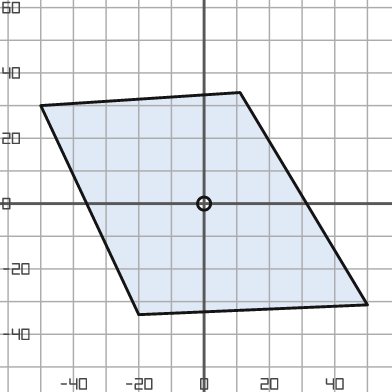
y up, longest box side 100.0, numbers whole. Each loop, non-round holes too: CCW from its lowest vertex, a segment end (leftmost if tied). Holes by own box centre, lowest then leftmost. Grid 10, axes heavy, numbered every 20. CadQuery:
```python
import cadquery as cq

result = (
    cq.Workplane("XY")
    .moveTo(-20.0, -34.0)
    .lineTo(50.0, -31.0)
    .lineTo(11.0, 34.0)
    .lineTo(-50.0, 30.0)
    .close()
    .moveTo(0.0, 0.0)
    .circle(2.0)
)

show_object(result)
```